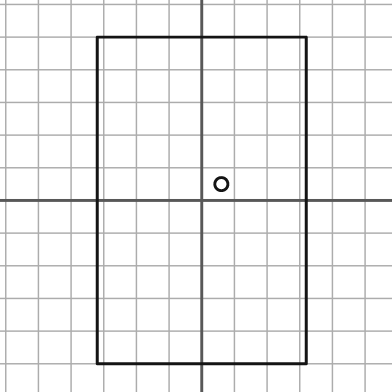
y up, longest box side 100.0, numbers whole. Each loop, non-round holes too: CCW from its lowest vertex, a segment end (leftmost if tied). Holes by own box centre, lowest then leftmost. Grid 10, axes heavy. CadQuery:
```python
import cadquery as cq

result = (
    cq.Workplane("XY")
    .moveTo(-32.0, -50.0)
    .lineTo(32.0, -50.0)
    .lineTo(32.0, 50.0)
    .lineTo(-32.0, 50.0)
    .close()
    .moveTo(6.0, 5.0)
    .circle(2.0)
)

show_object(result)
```